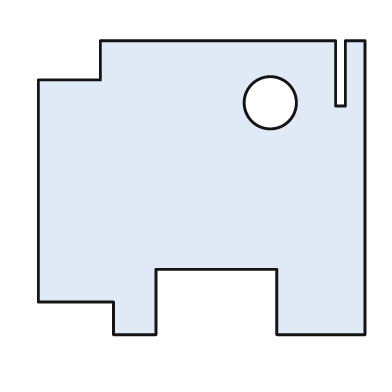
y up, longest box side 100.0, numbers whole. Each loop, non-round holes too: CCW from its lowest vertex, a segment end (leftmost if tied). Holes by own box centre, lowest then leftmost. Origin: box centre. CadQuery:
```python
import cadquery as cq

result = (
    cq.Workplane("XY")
    .moveTo(-27.0, -45.0)
    .lineTo(-14.0, -45.0)
    .lineTo(-14.0, -25.0)
    .lineTo(23.0, -25.0)
    .lineTo(23.0, -45.0)
    .lineTo(50.0, -45.0)
    .lineTo(50.0, 45.0)
    .lineTo(44.0, 45.0)
    .lineTo(44.0, 25.0)
    .lineTo(41.0, 25.0)
    .lineTo(41.0, 45.0)
    .lineTo(-31.0, 45.0)
    .lineTo(-31.0, 33.0)
    .lineTo(-50.0, 33.0)
    .lineTo(-50.0, -35.0)
    .lineTo(-27.0, -35.0)
    .close()
    .moveTo(21.0, 26.0)
    .circle(8.0)
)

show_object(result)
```